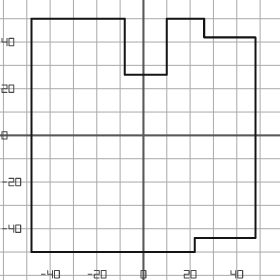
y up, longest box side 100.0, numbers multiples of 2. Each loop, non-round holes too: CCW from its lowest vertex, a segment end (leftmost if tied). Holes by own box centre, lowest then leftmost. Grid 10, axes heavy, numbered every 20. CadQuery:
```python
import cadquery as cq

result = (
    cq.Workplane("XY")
    .moveTo(-48.0, -50.0)
    .lineTo(22.0, -50.0)
    .lineTo(22.0, -44.0)
    .lineTo(48.0, -44.0)
    .lineTo(48.0, 42.0)
    .lineTo(26.0, 42.0)
    .lineTo(26.0, 50.0)
    .lineTo(10.0, 50.0)
    .lineTo(10.0, 26.0)
    .lineTo(-8.0, 26.0)
    .lineTo(-8.0, 50.0)
    .lineTo(-48.0, 50.0)
    .close()
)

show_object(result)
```